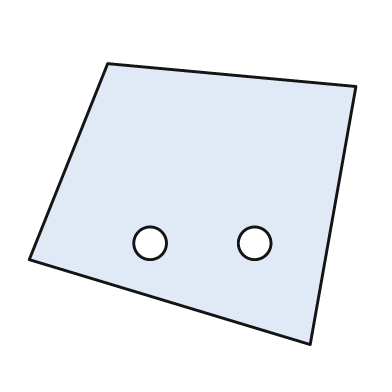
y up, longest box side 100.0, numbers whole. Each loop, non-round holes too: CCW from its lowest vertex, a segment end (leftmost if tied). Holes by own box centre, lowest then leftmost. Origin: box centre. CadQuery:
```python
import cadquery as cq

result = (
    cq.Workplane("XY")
    .moveTo(36.0, -43.0)
    .lineTo(50.0, 36.0)
    .lineTo(-26.0, 43.0)
    .lineTo(-50.0, -17.0)
    .close()
    .moveTo(-13.0, -12.0)
    .circle(5.0)
    .moveTo(19.0, -12.0)
    .circle(5.0)
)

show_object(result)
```